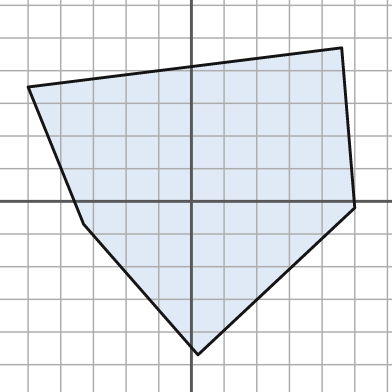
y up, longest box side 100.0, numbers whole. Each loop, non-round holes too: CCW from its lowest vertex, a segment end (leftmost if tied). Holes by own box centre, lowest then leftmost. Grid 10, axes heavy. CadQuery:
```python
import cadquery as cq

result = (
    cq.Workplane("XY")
    .moveTo(2.0, -47.0)
    .lineTo(50.0, -2.0)
    .lineTo(46.0, 47.0)
    .lineTo(-50.0, 35.0)
    .lineTo(-33.0, -7.0)
    .close()
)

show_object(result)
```